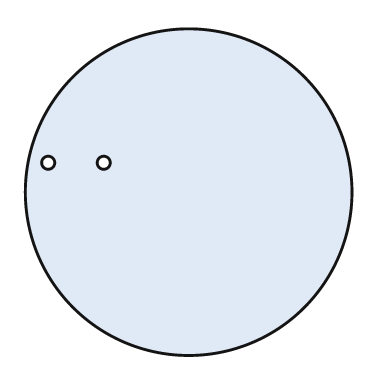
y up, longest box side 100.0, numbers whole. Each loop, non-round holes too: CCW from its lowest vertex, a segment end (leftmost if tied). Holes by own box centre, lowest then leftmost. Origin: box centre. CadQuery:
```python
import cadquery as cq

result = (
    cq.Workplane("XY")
    .moveTo(0.0, 0.0)
    .circle(50.0)
    .moveTo(-43.0, 9.0)
    .circle(2.0)
    .moveTo(-26.0, 9.0)
    .circle(2.0)
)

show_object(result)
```